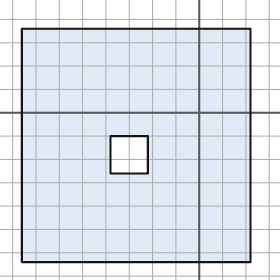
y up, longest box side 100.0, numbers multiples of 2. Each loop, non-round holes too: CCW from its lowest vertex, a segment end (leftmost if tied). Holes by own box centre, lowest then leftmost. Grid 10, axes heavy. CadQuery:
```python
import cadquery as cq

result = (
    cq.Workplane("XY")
    .moveTo(-76.0, -64.0)
    .lineTo(22.0, -64.0)
    .lineTo(22.0, 36.0)
    .lineTo(-76.0, 36.0)
    .close()
    .moveTo(-38.0, -26.0)
    .lineTo(-22.0, -26.0)
    .lineTo(-22.0, -10.0)
    .lineTo(-38.0, -10.0)
    .close()
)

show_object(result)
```